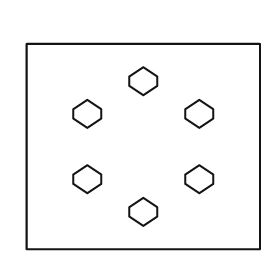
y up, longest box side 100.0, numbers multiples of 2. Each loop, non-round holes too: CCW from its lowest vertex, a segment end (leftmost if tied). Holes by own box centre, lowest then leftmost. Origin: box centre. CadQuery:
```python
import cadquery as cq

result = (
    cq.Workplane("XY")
    .moveTo(-50.0, -44.0)
    .lineTo(50.0, -44.0)
    .lineTo(50.0, 44.0)
    .lineTo(-50.0, 44.0)
    .close()
    .moveTo(0.0, -34.0)
    .lineTo(6.0, -30.0)
    .lineTo(6.0, -26.0)
    .lineTo(0.0, -22.0)
    .lineTo(-6.0, -26.0)
    .lineTo(-6.0, -30.0)
    .close()
    .moveTo(-24.0, -20.0)
    .lineTo(-18.0, -16.0)
    .lineTo(-18.0, -12.0)
    .lineTo(-24.0, -8.0)
    .lineTo(-30.0, -12.0)
    .lineTo(-30.0, -16.0)
    .close()
    .moveTo(24.0, -20.0)
    .lineTo(30.0, -16.0)
    .lineTo(30.0, -12.0)
    .lineTo(24.0, -8.0)
    .lineTo(18.0, -12.0)
    .lineTo(18.0, -16.0)
    .close()
    .moveTo(-24.0, 8.0)
    .lineTo(-18.0, 12.0)
    .lineTo(-18.0, 16.0)
    .lineTo(-24.0, 20.0)
    .lineTo(-30.0, 16.0)
    .lineTo(-30.0, 12.0)
    .close()
    .moveTo(24.0, 8.0)
    .lineTo(30.0, 12.0)
    .lineTo(30.0, 16.0)
    .lineTo(24.0, 20.0)
    .lineTo(18.0, 16.0)
    .lineTo(18.0, 12.0)
    .close()
    .moveTo(0.0, 22.0)
    .lineTo(6.0, 26.0)
    .lineTo(6.0, 30.0)
    .lineTo(0.0, 34.0)
    .lineTo(-6.0, 30.0)
    .lineTo(-6.0, 26.0)
    .close()
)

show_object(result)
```